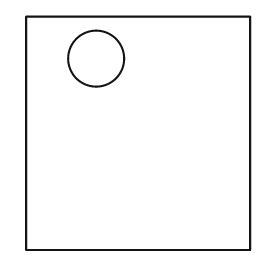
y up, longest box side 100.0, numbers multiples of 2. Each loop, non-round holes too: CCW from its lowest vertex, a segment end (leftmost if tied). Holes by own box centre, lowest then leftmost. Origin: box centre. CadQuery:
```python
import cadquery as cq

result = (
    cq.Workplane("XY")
    .moveTo(-48.0, -50.0)
    .lineTo(48.0, -50.0)
    .lineTo(48.0, 50.0)
    .lineTo(-48.0, 50.0)
    .close()
    .moveTo(-18.0, 32.0)
    .circle(12.0)
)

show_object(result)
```